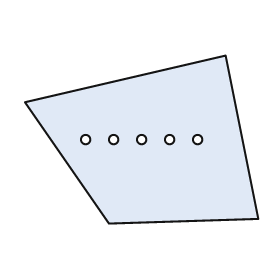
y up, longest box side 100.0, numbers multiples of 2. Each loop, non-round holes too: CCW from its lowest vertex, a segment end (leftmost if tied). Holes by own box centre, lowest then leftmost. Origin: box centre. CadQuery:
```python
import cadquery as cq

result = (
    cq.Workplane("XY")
    .moveTo(-14.0, -36.0)
    .lineTo(50.0, -34.0)
    .lineTo(36.0, 36.0)
    .lineTo(-50.0, 16.0)
    .close()
    .moveTo(-24.0, 0.0)
    .circle(2.0)
    .moveTo(-12.0, 0.0)
    .circle(2.0)
    .moveTo(0.0, 0.0)
    .circle(2.0)
    .moveTo(12.0, 0.0)
    .circle(2.0)
    .moveTo(24.0, 0.0)
    .circle(2.0)
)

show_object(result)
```